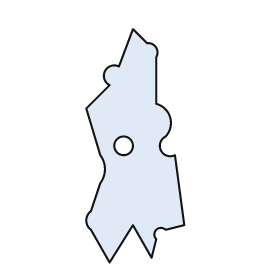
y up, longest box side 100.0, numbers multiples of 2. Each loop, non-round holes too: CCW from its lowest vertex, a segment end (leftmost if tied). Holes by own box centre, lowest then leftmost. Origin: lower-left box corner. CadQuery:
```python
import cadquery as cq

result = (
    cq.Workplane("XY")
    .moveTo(10.0, 0.0)
    .lineTo(20.0, 16.0)
    .lineTo(28.0, 2.0)
    .lineTo(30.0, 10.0)
    .threePointArc((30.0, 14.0), (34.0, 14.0))
    .lineTo(42.0, 16.0)
    .lineTo(38.0, 46.0)
    .threePointArc((32.0, 48.0), (34.0, 54.0))
    .threePointArc((36.0, 62.0), (30.0, 68.0))
    .lineTo(30.0, 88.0)
    .threePointArc((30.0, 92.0), (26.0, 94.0))
    .lineTo(20.0, 100.0)
    .lineTo(14.0, 84.0)
    .threePointArc((8.0, 82.0), (10.0, 76.0))
    .lineTo(0.0, 66.0)
    .lineTo(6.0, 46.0)
    .threePointArc((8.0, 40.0), (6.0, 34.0))
    .lineTo(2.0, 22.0)
    .threePointArc((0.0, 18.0), (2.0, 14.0))
    .close()
    .moveTo(16.0, 50.0)
    .circle(4.0)
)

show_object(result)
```